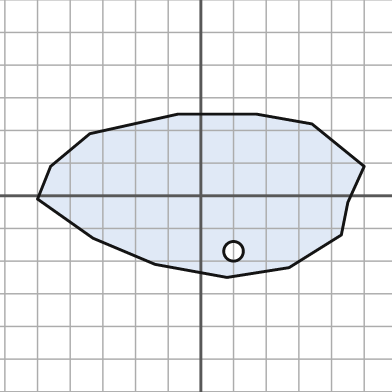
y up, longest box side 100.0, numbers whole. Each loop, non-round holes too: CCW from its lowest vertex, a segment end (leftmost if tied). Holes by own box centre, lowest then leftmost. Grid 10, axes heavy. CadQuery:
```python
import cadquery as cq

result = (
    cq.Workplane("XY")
    .moveTo(8.0, -25.0)
    .lineTo(27.0, -22.0)
    .lineTo(43.0, -12.0)
    .lineTo(45.0, -2.0)
    .lineTo(50.0, 9.0)
    .lineTo(34.0, 22.0)
    .lineTo(17.0, 25.0)
    .lineTo(-7.0, 25.0)
    .lineTo(-34.0, 19.0)
    .lineTo(-46.0, 9.0)
    .lineTo(-50.0, -1.0)
    .lineTo(-33.0, -13.0)
    .lineTo(-14.0, -21.0)
    .close()
    .moveTo(10.0, -17.0)
    .circle(3.0)
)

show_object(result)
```